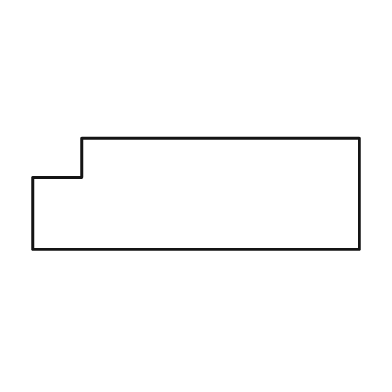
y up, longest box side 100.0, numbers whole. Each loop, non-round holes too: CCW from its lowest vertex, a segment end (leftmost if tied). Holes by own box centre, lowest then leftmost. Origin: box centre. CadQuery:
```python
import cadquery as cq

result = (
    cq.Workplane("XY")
    .moveTo(-50.0, -17.0)
    .lineTo(50.0, -17.0)
    .lineTo(50.0, 17.0)
    .lineTo(-35.0, 17.0)
    .lineTo(-35.0, 5.0)
    .lineTo(-50.0, 5.0)
    .close()
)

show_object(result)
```